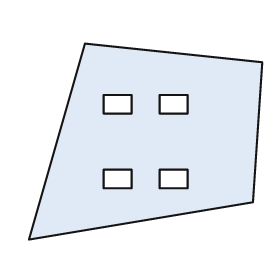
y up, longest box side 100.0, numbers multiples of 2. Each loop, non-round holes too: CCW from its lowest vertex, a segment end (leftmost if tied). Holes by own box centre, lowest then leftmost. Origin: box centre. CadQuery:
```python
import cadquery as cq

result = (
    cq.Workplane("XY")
    .moveTo(-50.0, -42.0)
    .lineTo(46.0, -26.0)
    .lineTo(50.0, 34.0)
    .lineTo(-26.0, 42.0)
    .close()
    .moveTo(-18.0, -20.0)
    .lineTo(-6.0, -20.0)
    .lineTo(-6.0, -12.0)
    .lineTo(-18.0, -12.0)
    .close()
    .moveTo(6.0, -20.0)
    .lineTo(18.0, -20.0)
    .lineTo(18.0, -12.0)
    .lineTo(6.0, -12.0)
    .close()
    .moveTo(-18.0, 12.0)
    .lineTo(-6.0, 12.0)
    .lineTo(-6.0, 20.0)
    .lineTo(-18.0, 20.0)
    .close()
    .moveTo(6.0, 12.0)
    .lineTo(18.0, 12.0)
    .lineTo(18.0, 20.0)
    .lineTo(6.0, 20.0)
    .close()
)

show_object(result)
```